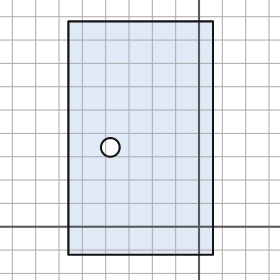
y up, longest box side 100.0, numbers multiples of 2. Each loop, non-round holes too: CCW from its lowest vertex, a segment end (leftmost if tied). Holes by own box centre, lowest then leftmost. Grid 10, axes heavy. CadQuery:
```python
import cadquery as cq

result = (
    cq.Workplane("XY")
    .moveTo(-56.0, -12.0)
    .lineTo(6.0, -12.0)
    .lineTo(6.0, 88.0)
    .lineTo(-56.0, 88.0)
    .close()
    .moveTo(-38.0, 34.0)
    .circle(4.0)
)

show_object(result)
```